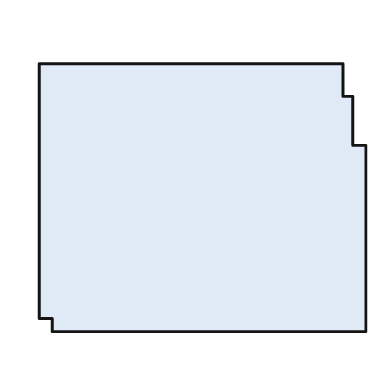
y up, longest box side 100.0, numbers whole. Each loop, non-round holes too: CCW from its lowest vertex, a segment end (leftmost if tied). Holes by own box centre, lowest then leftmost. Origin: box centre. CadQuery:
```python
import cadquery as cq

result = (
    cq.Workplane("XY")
    .moveTo(-46.0, -41.0)
    .lineTo(50.0, -41.0)
    .lineTo(50.0, 16.0)
    .lineTo(46.0, 16.0)
    .lineTo(46.0, 31.0)
    .lineTo(43.0, 31.0)
    .lineTo(43.0, 41.0)
    .lineTo(-50.0, 41.0)
    .lineTo(-50.0, -37.0)
    .lineTo(-46.0, -37.0)
    .close()
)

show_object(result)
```